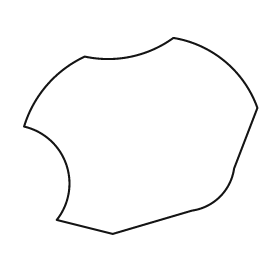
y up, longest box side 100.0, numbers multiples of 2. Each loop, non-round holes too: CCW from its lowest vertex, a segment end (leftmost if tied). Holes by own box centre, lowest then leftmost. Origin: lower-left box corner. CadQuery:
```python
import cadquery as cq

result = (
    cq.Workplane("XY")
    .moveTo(38.0, 0.0)
    .lineTo(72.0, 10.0)
    .threePointArc((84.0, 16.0), (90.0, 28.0))
    .lineTo(100.0, 54.0)
    .threePointArc((86.0, 74.0), (64.0, 84.0))
    .threePointArc((46.0, 76.0), (26.0, 76.0))
    .threePointArc((10.0, 64.0), (0.0, 46.0))
    .threePointArc((18.0, 30.0), (14.0, 6.0))
    .close()
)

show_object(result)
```